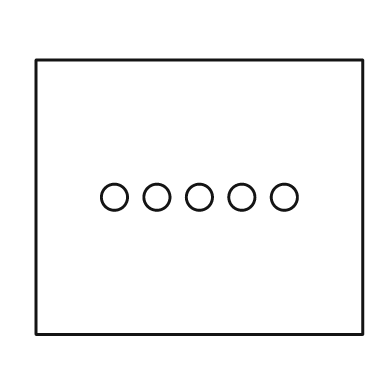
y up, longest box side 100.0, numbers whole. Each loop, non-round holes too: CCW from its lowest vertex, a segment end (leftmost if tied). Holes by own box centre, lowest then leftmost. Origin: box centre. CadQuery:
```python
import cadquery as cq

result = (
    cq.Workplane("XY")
    .moveTo(-50.0, -42.0)
    .lineTo(50.0, -42.0)
    .lineTo(50.0, 42.0)
    .lineTo(-50.0, 42.0)
    .close()
    .moveTo(-26.0, 0.0)
    .circle(4.0)
    .moveTo(-13.0, 0.0)
    .circle(4.0)
    .moveTo(0.0, 0.0)
    .circle(4.0)
    .moveTo(13.0, 0.0)
    .circle(4.0)
    .moveTo(26.0, 0.0)
    .circle(4.0)
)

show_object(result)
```